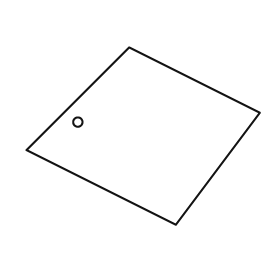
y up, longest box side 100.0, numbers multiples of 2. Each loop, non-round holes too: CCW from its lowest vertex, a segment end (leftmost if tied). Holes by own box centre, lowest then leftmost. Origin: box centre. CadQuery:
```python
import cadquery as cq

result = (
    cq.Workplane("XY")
    .moveTo(14.0, -38.0)
    .lineTo(50.0, 10.0)
    .lineTo(-6.0, 38.0)
    .lineTo(-50.0, -6.0)
    .close()
    .moveTo(-28.0, 6.0)
    .circle(2.0)
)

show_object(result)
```